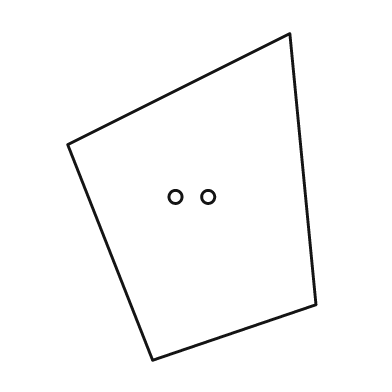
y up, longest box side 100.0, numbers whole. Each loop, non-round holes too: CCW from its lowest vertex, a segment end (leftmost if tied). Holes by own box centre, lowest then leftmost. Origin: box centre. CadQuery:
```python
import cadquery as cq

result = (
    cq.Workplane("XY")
    .moveTo(-12.0, -50.0)
    .lineTo(38.0, -33.0)
    .lineTo(30.0, 50.0)
    .lineTo(-38.0, 16.0)
    .close()
    .moveTo(-5.0, 0.0)
    .circle(2.0)
    .moveTo(5.0, 0.0)
    .circle(2.0)
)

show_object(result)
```